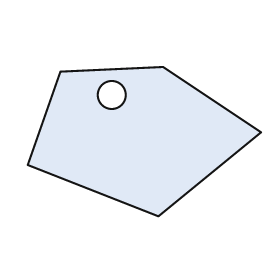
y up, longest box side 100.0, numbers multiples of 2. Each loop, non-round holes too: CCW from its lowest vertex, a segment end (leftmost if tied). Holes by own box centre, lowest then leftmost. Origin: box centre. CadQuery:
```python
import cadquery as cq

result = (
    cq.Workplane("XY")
    .moveTo(6.0, -32.0)
    .lineTo(50.0, 4.0)
    .lineTo(8.0, 32.0)
    .lineTo(-36.0, 30.0)
    .lineTo(-50.0, -10.0)
    .close()
    .moveTo(-14.0, 20.0)
    .circle(6.0)
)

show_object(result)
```